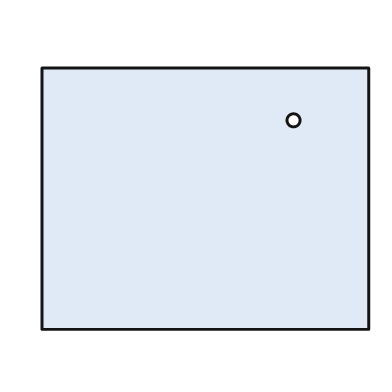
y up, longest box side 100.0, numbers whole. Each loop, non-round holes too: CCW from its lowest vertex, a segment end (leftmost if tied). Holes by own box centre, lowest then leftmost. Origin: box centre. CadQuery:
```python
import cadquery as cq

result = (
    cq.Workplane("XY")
    .moveTo(-50.0, -40.0)
    .lineTo(50.0, -40.0)
    .lineTo(50.0, 40.0)
    .lineTo(-50.0, 40.0)
    .close()
    .moveTo(27.0, 24.0)
    .circle(2.0)
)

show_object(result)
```